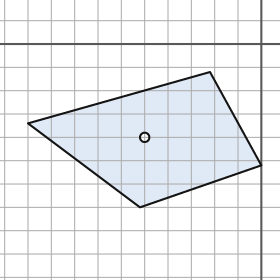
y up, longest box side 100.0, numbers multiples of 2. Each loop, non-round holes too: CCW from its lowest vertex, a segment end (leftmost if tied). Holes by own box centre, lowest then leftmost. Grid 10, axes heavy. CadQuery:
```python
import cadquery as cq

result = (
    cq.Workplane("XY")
    .moveTo(-52.0, -70.0)
    .lineTo(0.0, -52.0)
    .lineTo(-22.0, -12.0)
    .lineTo(-100.0, -34.0)
    .close()
    .moveTo(-50.0, -40.0)
    .circle(2.0)
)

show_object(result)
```